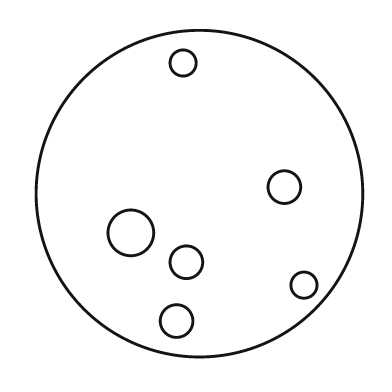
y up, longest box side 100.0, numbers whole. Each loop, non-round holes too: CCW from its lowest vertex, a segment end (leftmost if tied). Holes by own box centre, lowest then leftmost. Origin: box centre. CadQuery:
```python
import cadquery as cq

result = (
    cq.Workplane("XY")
    .moveTo(0.0, 0.0)
    .circle(50.0)
    .moveTo(-7.0, -39.0)
    .circle(5.0)
    .moveTo(32.0, -28.0)
    .circle(4.0)
    .moveTo(-4.0, -21.0)
    .circle(5.0)
    .moveTo(-21.0, -12.0)
    .circle(7.0)
    .moveTo(26.0, 2.0)
    .circle(5.0)
    .moveTo(-5.0, 40.0)
    .circle(4.0)
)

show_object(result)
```